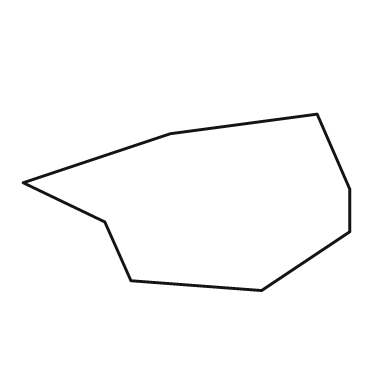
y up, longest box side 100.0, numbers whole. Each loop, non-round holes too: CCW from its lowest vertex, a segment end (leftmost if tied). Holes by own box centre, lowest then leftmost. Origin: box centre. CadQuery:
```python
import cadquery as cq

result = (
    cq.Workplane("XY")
    .moveTo(23.0, -27.0)
    .lineTo(50.0, -9.0)
    .lineTo(50.0, 4.0)
    .lineTo(40.0, 27.0)
    .lineTo(-5.0, 21.0)
    .lineTo(-50.0, 6.0)
    .lineTo(-25.0, -6.0)
    .lineTo(-17.0, -24.0)
    .close()
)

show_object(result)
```